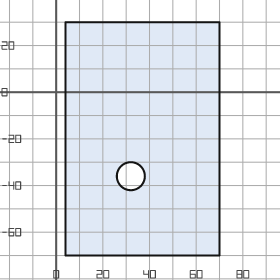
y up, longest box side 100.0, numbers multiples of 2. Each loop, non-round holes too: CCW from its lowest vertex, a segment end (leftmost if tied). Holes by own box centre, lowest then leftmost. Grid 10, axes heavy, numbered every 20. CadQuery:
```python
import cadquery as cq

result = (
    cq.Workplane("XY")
    .moveTo(4.0, -70.0)
    .lineTo(70.0, -70.0)
    .lineTo(70.0, 30.0)
    .lineTo(4.0, 30.0)
    .close()
    .moveTo(32.0, -36.0)
    .circle(6.0)
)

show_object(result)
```